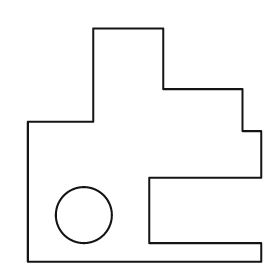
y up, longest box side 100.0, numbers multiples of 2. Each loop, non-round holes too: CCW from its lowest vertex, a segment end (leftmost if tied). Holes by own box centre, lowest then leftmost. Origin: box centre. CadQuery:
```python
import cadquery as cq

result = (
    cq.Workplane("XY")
    .moveTo(-50.0, -50.0)
    .lineTo(50.0, -50.0)
    .lineTo(50.0, -42.0)
    .lineTo(2.0, -42.0)
    .lineTo(2.0, -14.0)
    .lineTo(50.0, -14.0)
    .lineTo(50.0, 6.0)
    .lineTo(42.0, 6.0)
    .lineTo(42.0, 24.0)
    .lineTo(8.0, 24.0)
    .lineTo(8.0, 50.0)
    .lineTo(-22.0, 50.0)
    .lineTo(-22.0, 10.0)
    .lineTo(-50.0, 10.0)
    .close()
    .moveTo(-26.0, -30.0)
    .circle(12.0)
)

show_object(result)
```